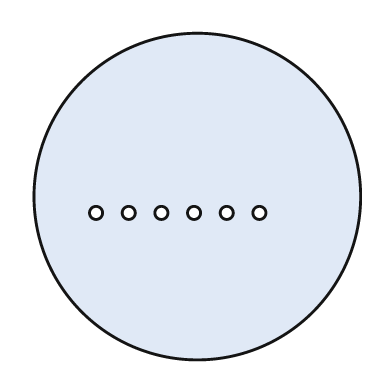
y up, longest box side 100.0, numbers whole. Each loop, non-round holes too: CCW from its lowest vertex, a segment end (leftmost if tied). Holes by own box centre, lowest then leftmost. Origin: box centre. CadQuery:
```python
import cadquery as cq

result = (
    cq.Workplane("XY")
    .moveTo(0.0, 0.0)
    .circle(50.0)
    .moveTo(-31.0, -5.0)
    .circle(2.0)
    .moveTo(-21.0, -5.0)
    .circle(2.0)
    .moveTo(-11.0, -5.0)
    .circle(2.0)
    .moveTo(-1.0, -5.0)
    .circle(2.0)
    .moveTo(9.0, -5.0)
    .circle(2.0)
    .moveTo(19.0, -5.0)
    .circle(2.0)
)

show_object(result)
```